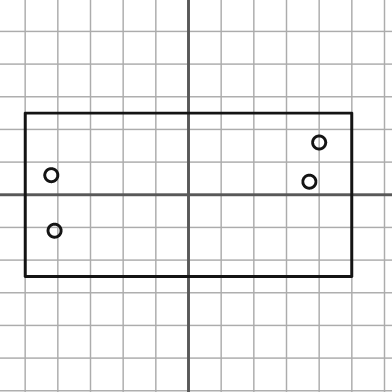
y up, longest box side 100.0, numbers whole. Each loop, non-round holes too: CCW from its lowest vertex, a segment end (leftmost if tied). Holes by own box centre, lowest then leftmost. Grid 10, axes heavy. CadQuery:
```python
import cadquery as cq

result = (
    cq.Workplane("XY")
    .moveTo(-50.0, -25.0)
    .lineTo(50.0, -25.0)
    .lineTo(50.0, 25.0)
    .lineTo(-50.0, 25.0)
    .close()
    .moveTo(-41.0, -11.0)
    .circle(2.0)
    .moveTo(37.0, 4.0)
    .circle(2.0)
    .moveTo(-42.0, 6.0)
    .circle(2.0)
    .moveTo(40.0, 16.0)
    .circle(2.0)
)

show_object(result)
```